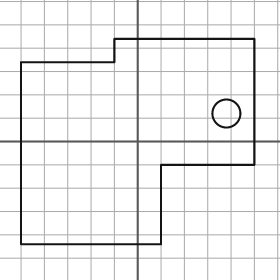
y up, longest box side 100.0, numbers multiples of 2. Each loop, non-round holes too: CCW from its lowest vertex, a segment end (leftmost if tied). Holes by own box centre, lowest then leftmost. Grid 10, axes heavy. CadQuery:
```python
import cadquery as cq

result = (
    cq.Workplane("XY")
    .moveTo(-50.0, -44.0)
    .lineTo(10.0, -44.0)
    .lineTo(10.0, -10.0)
    .lineTo(50.0, -10.0)
    .lineTo(50.0, 44.0)
    .lineTo(-10.0, 44.0)
    .lineTo(-10.0, 34.0)
    .lineTo(-50.0, 34.0)
    .close()
    .moveTo(38.0, 12.0)
    .circle(6.0)
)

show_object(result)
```